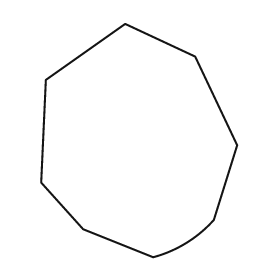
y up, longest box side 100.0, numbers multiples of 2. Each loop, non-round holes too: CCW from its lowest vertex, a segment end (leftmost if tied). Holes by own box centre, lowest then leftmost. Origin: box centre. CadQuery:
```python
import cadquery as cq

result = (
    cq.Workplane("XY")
    .moveTo(6.0, -50.0)
    .threePointArc((20.0, -44.0), (32.0, -34.0))
    .lineTo(42.0, -2.0)
    .lineTo(24.0, 36.0)
    .lineTo(-6.0, 50.0)
    .lineTo(-40.0, 26.0)
    .lineTo(-42.0, -18.0)
    .lineTo(-24.0, -38.0)
    .close()
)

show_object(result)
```